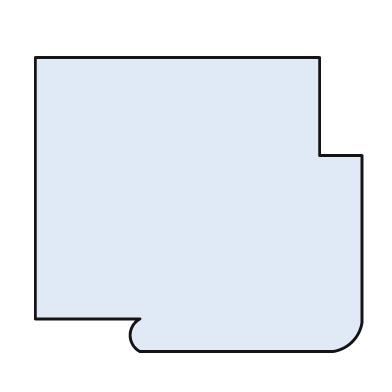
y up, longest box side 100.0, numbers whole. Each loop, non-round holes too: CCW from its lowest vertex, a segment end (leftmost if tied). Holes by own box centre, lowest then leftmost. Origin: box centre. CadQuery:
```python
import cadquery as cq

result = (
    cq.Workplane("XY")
    .moveTo(-18.0, -45.0)
    .lineTo(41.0, -45.0)
    .threePointArc((47.0, -42.0), (50.0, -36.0))
    .lineTo(50.0, 15.0)
    .lineTo(37.0, 15.0)
    .lineTo(37.0, 45.0)
    .lineTo(-50.0, 45.0)
    .lineTo(-50.0, -35.0)
    .lineTo(-18.0, -35.0)
    .threePointArc((-21.0, -40.0), (-18.0, -45.0))
    .close()
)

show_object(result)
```